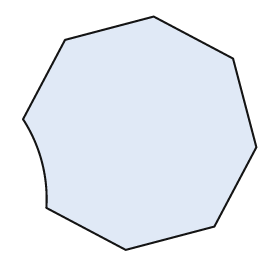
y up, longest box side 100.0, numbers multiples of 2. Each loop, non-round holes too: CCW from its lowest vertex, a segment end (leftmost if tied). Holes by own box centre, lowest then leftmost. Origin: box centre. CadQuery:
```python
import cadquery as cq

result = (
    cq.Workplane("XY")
    .moveTo(-6.0, -50.0)
    .lineTo(32.0, -40.0)
    .lineTo(50.0, -6.0)
    .lineTo(40.0, 32.0)
    .lineTo(6.0, 50.0)
    .lineTo(-32.0, 40.0)
    .lineTo(-50.0, 6.0)
    .threePointArc((-42.0, -12.0), (-40.0, -32.0))
    .close()
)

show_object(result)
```